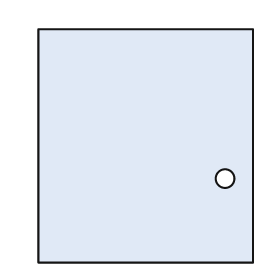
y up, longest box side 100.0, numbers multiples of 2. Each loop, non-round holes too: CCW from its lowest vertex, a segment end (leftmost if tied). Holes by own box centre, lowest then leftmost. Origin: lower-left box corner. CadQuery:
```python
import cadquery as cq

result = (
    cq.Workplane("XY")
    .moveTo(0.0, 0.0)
    .lineTo(92.0, 0.0)
    .lineTo(92.0, 100.0)
    .lineTo(0.0, 100.0)
    .close()
    .moveTo(80.0, 36.0)
    .circle(4.0)
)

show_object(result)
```